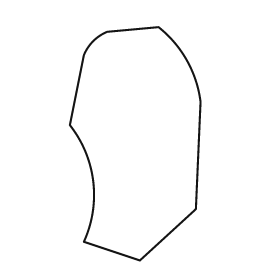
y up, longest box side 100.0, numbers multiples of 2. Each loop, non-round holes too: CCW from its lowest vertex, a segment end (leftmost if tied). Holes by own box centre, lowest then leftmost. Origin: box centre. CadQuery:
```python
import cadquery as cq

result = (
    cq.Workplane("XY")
    .moveTo(2.0, -50.0)
    .lineTo(26.0, -28.0)
    .lineTo(28.0, 18.0)
    .threePointArc((22.0, 36.0), (10.0, 50.0))
    .lineTo(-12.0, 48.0)
    .threePointArc((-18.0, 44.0), (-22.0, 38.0))
    .lineTo(-28.0, 8.0)
    .threePointArc((-18.0, -16.0), (-22.0, -42.0))
    .close()
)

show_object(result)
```